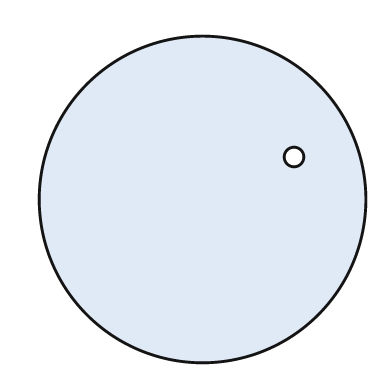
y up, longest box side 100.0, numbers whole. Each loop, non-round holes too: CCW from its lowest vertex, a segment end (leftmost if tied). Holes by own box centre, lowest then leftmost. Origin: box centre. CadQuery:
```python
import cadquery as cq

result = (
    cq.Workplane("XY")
    .moveTo(0.0, 0.0)
    .circle(50.0)
    .moveTo(28.0, 13.0)
    .circle(3.0)
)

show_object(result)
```